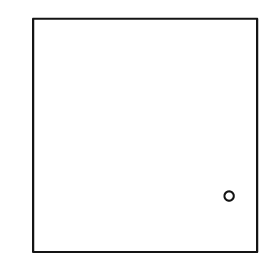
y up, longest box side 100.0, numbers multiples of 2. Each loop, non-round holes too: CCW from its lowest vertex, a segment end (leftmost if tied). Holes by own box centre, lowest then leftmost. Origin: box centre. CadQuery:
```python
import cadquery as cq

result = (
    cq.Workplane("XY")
    .moveTo(-48.0, -50.0)
    .lineTo(48.0, -50.0)
    .lineTo(48.0, 50.0)
    .lineTo(-48.0, 50.0)
    .close()
    .moveTo(36.0, -26.0)
    .circle(2.0)
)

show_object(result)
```